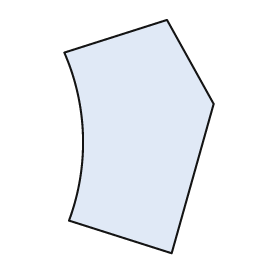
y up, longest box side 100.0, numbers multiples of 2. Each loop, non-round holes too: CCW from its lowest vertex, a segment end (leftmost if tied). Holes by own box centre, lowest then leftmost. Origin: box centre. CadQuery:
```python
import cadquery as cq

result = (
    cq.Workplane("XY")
    .moveTo(14.0, -50.0)
    .lineTo(32.0, 14.0)
    .lineTo(12.0, 50.0)
    .lineTo(-32.0, 36.0)
    .threePointArc((-24.0, 0.0), (-30.0, -36.0))
    .close()
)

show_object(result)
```